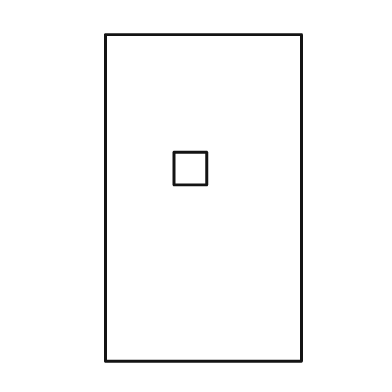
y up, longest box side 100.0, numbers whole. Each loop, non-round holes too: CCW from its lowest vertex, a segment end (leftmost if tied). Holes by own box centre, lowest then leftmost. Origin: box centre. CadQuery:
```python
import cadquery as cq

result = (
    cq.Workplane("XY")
    .moveTo(-30.0, -50.0)
    .lineTo(30.0, -50.0)
    .lineTo(30.0, 50.0)
    .lineTo(-30.0, 50.0)
    .close()
    .moveTo(-9.0, 4.0)
    .lineTo(1.0, 4.0)
    .lineTo(1.0, 14.0)
    .lineTo(-9.0, 14.0)
    .close()
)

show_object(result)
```